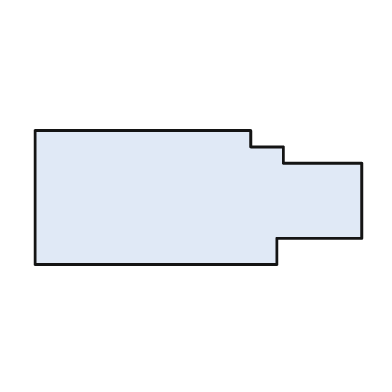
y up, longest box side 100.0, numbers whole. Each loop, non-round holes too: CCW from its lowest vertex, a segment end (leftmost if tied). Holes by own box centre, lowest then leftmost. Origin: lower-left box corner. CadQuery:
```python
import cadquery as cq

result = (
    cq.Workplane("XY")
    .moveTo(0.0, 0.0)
    .lineTo(74.0, 0.0)
    .lineTo(74.0, 8.0)
    .lineTo(100.0, 8.0)
    .lineTo(100.0, 31.0)
    .lineTo(76.0, 31.0)
    .lineTo(76.0, 36.0)
    .lineTo(66.0, 36.0)
    .lineTo(66.0, 41.0)
    .lineTo(0.0, 41.0)
    .close()
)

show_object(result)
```